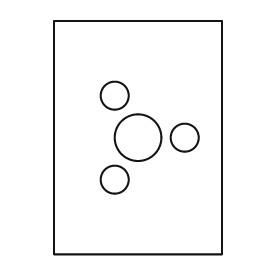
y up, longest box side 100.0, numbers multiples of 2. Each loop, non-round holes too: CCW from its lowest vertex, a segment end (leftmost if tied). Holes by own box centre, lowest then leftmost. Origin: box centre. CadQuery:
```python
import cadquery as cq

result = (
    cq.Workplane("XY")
    .moveTo(-36.0, -50.0)
    .lineTo(36.0, -50.0)
    .lineTo(36.0, 50.0)
    .lineTo(-36.0, 50.0)
    .close()
    .moveTo(-10.0, -18.0)
    .circle(6.0)
    .moveTo(0.0, 0.0)
    .circle(10.0)
    .moveTo(20.0, 0.0)
    .circle(6.0)
    .moveTo(-10.0, 18.0)
    .circle(6.0)
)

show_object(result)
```